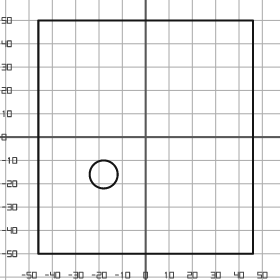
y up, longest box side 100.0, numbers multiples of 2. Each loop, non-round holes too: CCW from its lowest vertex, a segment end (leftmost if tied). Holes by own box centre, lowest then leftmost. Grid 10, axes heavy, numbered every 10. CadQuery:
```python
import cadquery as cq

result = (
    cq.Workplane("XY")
    .moveTo(-46.0, -50.0)
    .lineTo(46.0, -50.0)
    .lineTo(46.0, 50.0)
    .lineTo(-46.0, 50.0)
    .close()
    .moveTo(-18.0, -16.0)
    .circle(6.0)
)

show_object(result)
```